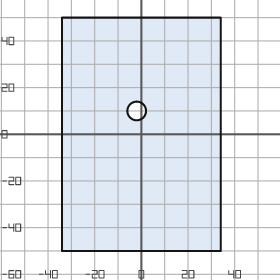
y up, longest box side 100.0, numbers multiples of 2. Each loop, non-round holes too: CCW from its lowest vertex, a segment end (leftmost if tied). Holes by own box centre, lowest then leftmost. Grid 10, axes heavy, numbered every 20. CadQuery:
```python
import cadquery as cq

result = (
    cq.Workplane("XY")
    .moveTo(-34.0, -50.0)
    .lineTo(34.0, -50.0)
    .lineTo(34.0, 50.0)
    .lineTo(-34.0, 50.0)
    .close()
    .moveTo(-2.0, 10.0)
    .circle(4.0)
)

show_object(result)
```